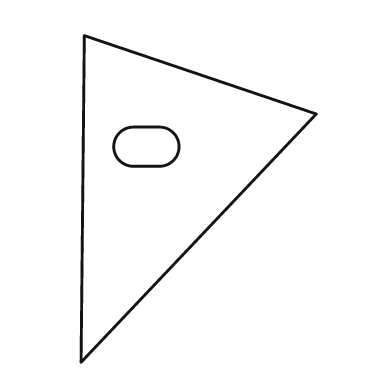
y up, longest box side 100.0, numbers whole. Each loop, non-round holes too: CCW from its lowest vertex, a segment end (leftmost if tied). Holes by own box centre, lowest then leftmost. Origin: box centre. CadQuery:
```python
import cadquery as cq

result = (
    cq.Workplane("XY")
    .moveTo(-36.0, -50.0)
    .lineTo(36.0, 26.0)
    .lineTo(-35.0, 50.0)
    .close()
    .moveTo(-20.0, 10.0)
    .lineTo(-12.0, 10.0)
    .threePointArc((-6.0, 16.0), (-12.0, 22.0))
    .lineTo(-20.0, 22.0)
    .threePointArc((-26.0, 16.0), (-20.0, 10.0))
    .close()
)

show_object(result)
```